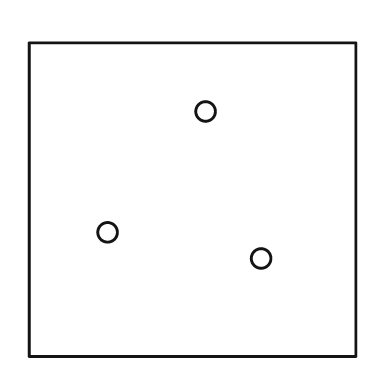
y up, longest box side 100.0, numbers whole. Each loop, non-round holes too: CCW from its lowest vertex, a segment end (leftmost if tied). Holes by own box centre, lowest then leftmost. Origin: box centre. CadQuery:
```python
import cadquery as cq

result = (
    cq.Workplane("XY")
    .moveTo(-50.0, -48.0)
    .lineTo(50.0, -48.0)
    .lineTo(50.0, 48.0)
    .lineTo(-50.0, 48.0)
    .close()
    .moveTo(21.0, -18.0)
    .circle(3.0)
    .moveTo(-26.0, -10.0)
    .circle(3.0)
    .moveTo(4.0, 27.0)
    .circle(3.0)
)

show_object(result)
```